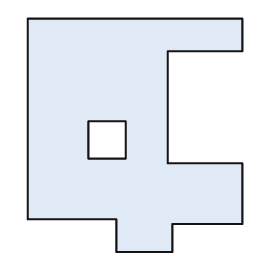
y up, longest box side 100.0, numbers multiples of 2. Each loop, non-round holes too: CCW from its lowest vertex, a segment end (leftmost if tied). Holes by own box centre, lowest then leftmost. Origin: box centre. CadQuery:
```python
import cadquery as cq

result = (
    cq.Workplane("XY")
    .moveTo(-8.0, -50.0)
    .lineTo(16.0, -50.0)
    .lineTo(16.0, -38.0)
    .lineTo(46.0, -38.0)
    .lineTo(46.0, -12.0)
    .lineTo(14.0, -12.0)
    .lineTo(14.0, 36.0)
    .lineTo(46.0, 36.0)
    .lineTo(46.0, 50.0)
    .lineTo(-46.0, 50.0)
    .lineTo(-46.0, -36.0)
    .lineTo(-8.0, -36.0)
    .close()
    .moveTo(-20.0, -10.0)
    .lineTo(-4.0, -10.0)
    .lineTo(-4.0, 6.0)
    .lineTo(-20.0, 6.0)
    .close()
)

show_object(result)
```